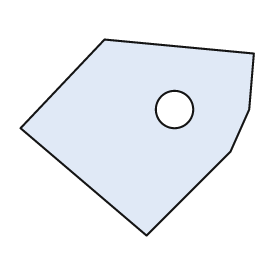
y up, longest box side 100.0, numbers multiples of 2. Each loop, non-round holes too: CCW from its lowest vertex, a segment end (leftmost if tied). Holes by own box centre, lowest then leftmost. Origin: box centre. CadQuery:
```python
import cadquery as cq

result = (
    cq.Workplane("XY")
    .moveTo(4.0, -42.0)
    .lineTo(40.0, -6.0)
    .lineTo(48.0, 12.0)
    .lineTo(50.0, 36.0)
    .lineTo(-14.0, 42.0)
    .lineTo(-50.0, 4.0)
    .close()
    .moveTo(16.0, 12.0)
    .circle(8.0)
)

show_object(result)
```